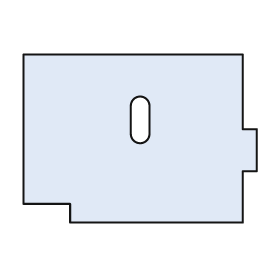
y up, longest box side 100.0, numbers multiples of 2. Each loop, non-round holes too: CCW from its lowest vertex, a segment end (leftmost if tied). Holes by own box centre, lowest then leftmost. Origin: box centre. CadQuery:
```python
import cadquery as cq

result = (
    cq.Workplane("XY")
    .moveTo(-30.0, -36.0)
    .lineTo(44.0, -36.0)
    .lineTo(44.0, -14.0)
    .lineTo(50.0, -14.0)
    .lineTo(50.0, 4.0)
    .lineTo(44.0, 4.0)
    .lineTo(44.0, 36.0)
    .lineTo(-50.0, 36.0)
    .lineTo(-50.0, -28.0)
    .lineTo(-30.0, -28.0)
    .close()
    .moveTo(-4.0, 2.0)
    .threePointArc((0.0, -2.0), (4.0, 2.0))
    .lineTo(4.0, 14.0)
    .threePointArc((0.0, 18.0), (-4.0, 14.0))
    .close()
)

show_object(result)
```